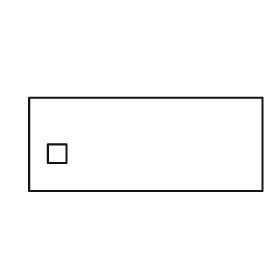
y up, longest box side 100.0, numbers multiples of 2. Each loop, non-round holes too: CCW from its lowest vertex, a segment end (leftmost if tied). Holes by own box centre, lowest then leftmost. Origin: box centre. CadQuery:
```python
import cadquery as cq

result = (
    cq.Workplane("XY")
    .moveTo(-50.0, -20.0)
    .lineTo(50.0, -20.0)
    .lineTo(50.0, 20.0)
    .lineTo(-50.0, 20.0)
    .close()
    .moveTo(-42.0, -8.0)
    .lineTo(-34.0, -8.0)
    .lineTo(-34.0, 0.0)
    .lineTo(-42.0, 0.0)
    .close()
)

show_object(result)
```